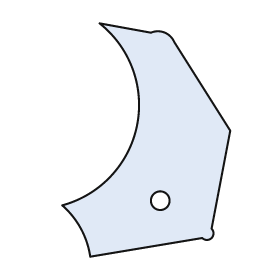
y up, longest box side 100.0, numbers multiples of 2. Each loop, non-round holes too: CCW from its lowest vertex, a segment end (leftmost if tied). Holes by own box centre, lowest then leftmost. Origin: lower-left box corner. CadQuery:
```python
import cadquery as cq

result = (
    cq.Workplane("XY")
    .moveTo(12.0, 0.0)
    .lineTo(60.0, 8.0)
    .threePointArc((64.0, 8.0), (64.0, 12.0))
    .lineTo(72.0, 54.0)
    .lineTo(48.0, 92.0)
    .threePointArc((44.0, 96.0), (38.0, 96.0))
    .lineTo(16.0, 100.0)
    .threePointArc((32.0, 56.0), (0.0, 22.0))
    .threePointArc((8.0, 12.0), (12.0, 0.0))
    .close()
    .moveTo(42.0, 24.0)
    .circle(4.0)
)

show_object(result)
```